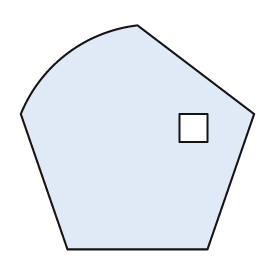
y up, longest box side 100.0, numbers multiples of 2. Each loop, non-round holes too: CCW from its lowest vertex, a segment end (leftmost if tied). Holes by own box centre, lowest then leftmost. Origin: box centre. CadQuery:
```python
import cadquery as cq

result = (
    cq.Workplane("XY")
    .moveTo(-30.0, -48.0)
    .lineTo(30.0, -48.0)
    .lineTo(50.0, 10.0)
    .lineTo(0.0, 48.0)
    .threePointArc((-30.0, 36.0), (-50.0, 10.0))
    .close()
    .moveTo(18.0, -2.0)
    .lineTo(30.0, -2.0)
    .lineTo(30.0, 10.0)
    .lineTo(18.0, 10.0)
    .close()
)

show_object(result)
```